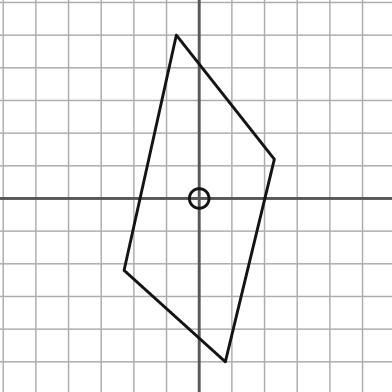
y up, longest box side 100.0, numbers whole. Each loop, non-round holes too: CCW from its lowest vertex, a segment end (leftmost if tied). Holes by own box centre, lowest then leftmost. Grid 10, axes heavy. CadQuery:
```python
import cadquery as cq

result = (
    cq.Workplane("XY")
    .moveTo(8.0, -50.0)
    .lineTo(23.0, 12.0)
    .lineTo(-7.0, 50.0)
    .lineTo(-23.0, -22.0)
    .close()
    .moveTo(0.0, 0.0)
    .circle(3.0)
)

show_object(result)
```